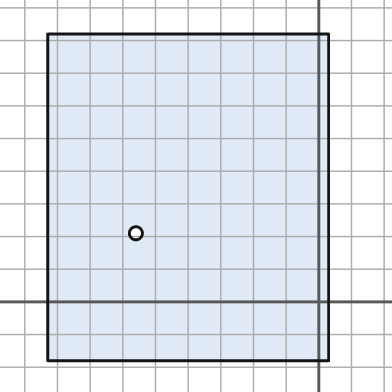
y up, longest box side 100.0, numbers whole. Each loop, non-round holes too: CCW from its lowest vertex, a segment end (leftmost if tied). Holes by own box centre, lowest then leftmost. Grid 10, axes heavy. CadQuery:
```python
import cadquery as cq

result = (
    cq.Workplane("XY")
    .moveTo(-83.0, -18.0)
    .lineTo(3.0, -18.0)
    .lineTo(3.0, 82.0)
    .lineTo(-83.0, 82.0)
    .close()
    .moveTo(-56.0, 21.0)
    .circle(2.0)
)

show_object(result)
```